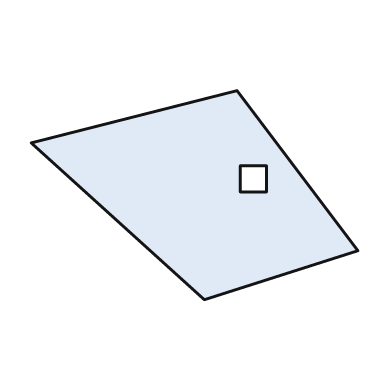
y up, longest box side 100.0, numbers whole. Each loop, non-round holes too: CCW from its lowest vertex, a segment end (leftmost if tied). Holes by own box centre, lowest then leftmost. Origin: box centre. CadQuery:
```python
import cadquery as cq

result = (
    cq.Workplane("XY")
    .moveTo(3.0, -32.0)
    .lineTo(50.0, -17.0)
    .lineTo(13.0, 32.0)
    .lineTo(-50.0, 16.0)
    .close()
    .moveTo(14.0, 1.0)
    .lineTo(22.0, 1.0)
    .lineTo(22.0, 9.0)
    .lineTo(14.0, 9.0)
    .close()
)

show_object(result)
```